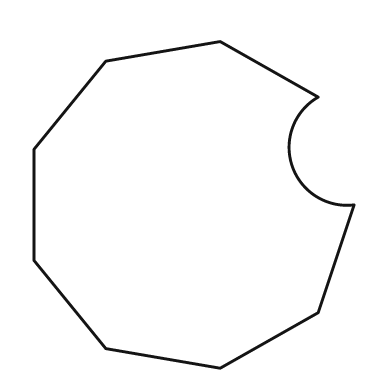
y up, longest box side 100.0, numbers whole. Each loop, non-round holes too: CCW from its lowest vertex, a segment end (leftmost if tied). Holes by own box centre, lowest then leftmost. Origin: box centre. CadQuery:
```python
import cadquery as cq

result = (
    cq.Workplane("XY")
    .moveTo(8.0, -50.0)
    .lineTo(38.0, -33.0)
    .lineTo(49.0, 0.0)
    .threePointArc((30.0, 12.0), (38.0, 33.0))
    .lineTo(8.0, 50.0)
    .lineTo(-27.0, 44.0)
    .lineTo(-49.0, 17.0)
    .lineTo(-49.0, -17.0)
    .lineTo(-27.0, -44.0)
    .close()
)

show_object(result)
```